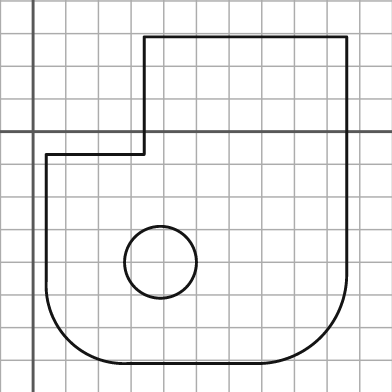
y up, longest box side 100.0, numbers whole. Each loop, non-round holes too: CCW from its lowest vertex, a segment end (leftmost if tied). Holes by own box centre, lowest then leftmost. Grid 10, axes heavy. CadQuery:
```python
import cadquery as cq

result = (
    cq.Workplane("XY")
    .moveTo(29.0, -71.0)
    .lineTo(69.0, -71.0)
    .threePointArc((88.0, -63.0), (96.0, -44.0))
    .lineTo(96.0, 29.0)
    .lineTo(34.0, 29.0)
    .lineTo(34.0, -7.0)
    .lineTo(4.0, -7.0)
    .lineTo(4.0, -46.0)
    .threePointArc((11.0, -64.0), (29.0, -71.0))
    .close()
    .moveTo(39.0, -40.0)
    .circle(11.0)
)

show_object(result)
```